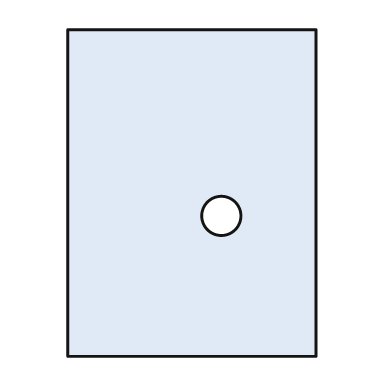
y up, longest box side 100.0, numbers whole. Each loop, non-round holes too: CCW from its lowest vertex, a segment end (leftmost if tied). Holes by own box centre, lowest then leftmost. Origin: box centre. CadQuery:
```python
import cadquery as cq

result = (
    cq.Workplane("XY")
    .moveTo(-38.0, -50.0)
    .lineTo(38.0, -50.0)
    .lineTo(38.0, 50.0)
    .lineTo(-38.0, 50.0)
    .close()
    .moveTo(9.0, -7.0)
    .circle(6.0)
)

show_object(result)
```